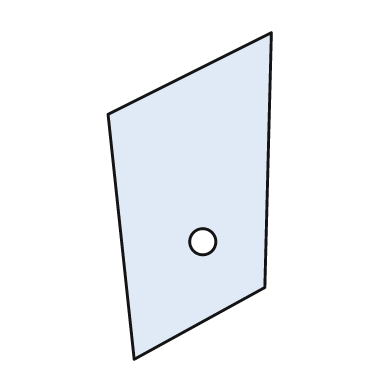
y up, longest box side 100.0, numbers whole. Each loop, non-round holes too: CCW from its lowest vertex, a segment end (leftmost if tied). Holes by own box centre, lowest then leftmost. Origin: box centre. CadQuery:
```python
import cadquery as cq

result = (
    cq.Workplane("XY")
    .moveTo(-17.0, -50.0)
    .lineTo(23.0, -28.0)
    .lineTo(25.0, 50.0)
    .lineTo(-25.0, 25.0)
    .close()
    .moveTo(4.0, -14.0)
    .circle(4.0)
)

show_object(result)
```